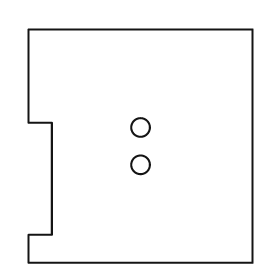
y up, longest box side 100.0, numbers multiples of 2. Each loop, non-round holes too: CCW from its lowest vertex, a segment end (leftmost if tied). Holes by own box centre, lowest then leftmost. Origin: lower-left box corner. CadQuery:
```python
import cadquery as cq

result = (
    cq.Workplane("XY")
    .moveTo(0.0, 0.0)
    .lineTo(96.0, 0.0)
    .lineTo(96.0, 100.0)
    .lineTo(0.0, 100.0)
    .lineTo(0.0, 60.0)
    .lineTo(10.0, 60.0)
    .lineTo(10.0, 12.0)
    .lineTo(0.0, 12.0)
    .close()
    .moveTo(48.0, 42.0)
    .circle(4.0)
    .moveTo(48.0, 58.0)
    .circle(4.0)
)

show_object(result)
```